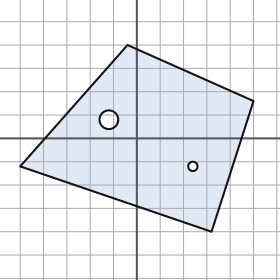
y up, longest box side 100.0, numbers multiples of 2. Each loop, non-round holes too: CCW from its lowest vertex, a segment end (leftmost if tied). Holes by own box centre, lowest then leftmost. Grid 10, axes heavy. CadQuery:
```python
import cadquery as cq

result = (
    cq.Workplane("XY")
    .moveTo(32.0, -40.0)
    .lineTo(50.0, 16.0)
    .lineTo(-4.0, 40.0)
    .lineTo(-50.0, -12.0)
    .close()
    .moveTo(24.0, -12.0)
    .circle(2.0)
    .moveTo(-12.0, 8.0)
    .circle(4.0)
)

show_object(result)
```